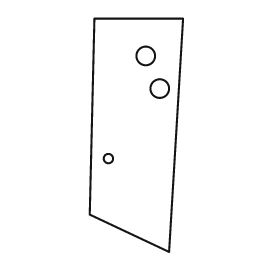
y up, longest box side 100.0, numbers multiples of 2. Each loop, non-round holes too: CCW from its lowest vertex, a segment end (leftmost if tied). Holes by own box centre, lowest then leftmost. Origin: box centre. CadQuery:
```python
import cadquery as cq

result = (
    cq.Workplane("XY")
    .moveTo(14.0, -50.0)
    .lineTo(20.0, 50.0)
    .lineTo(-18.0, 50.0)
    .lineTo(-20.0, -34.0)
    .close()
    .moveTo(-12.0, -10.0)
    .circle(2.0)
    .moveTo(10.0, 20.0)
    .circle(4.0)
    .moveTo(4.0, 34.0)
    .circle(4.0)
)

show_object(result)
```